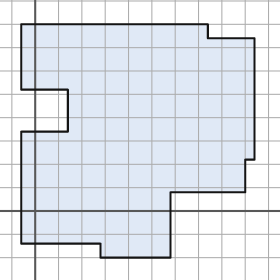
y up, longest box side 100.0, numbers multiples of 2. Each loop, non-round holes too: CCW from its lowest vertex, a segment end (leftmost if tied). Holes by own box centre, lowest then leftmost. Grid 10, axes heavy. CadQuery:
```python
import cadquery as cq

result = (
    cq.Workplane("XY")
    .moveTo(28.0, -20.0)
    .lineTo(58.0, -20.0)
    .lineTo(58.0, 8.0)
    .lineTo(90.0, 8.0)
    .lineTo(90.0, 22.0)
    .lineTo(94.0, 22.0)
    .lineTo(94.0, 74.0)
    .lineTo(74.0, 74.0)
    .lineTo(74.0, 80.0)
    .lineTo(-6.0, 80.0)
    .lineTo(-6.0, 52.0)
    .lineTo(14.0, 52.0)
    .lineTo(14.0, 34.0)
    .lineTo(-6.0, 34.0)
    .lineTo(-6.0, -14.0)
    .lineTo(28.0, -14.0)
    .close()
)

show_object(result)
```